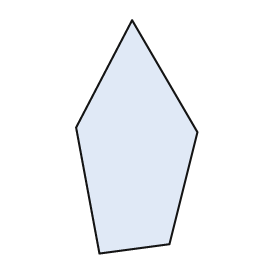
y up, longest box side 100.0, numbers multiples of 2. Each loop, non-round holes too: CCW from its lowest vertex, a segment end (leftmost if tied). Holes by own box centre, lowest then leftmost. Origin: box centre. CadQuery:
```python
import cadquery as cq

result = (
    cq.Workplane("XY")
    .moveTo(-16.0, -50.0)
    .lineTo(14.0, -46.0)
    .lineTo(26.0, 2.0)
    .lineTo(-2.0, 50.0)
    .lineTo(-26.0, 4.0)
    .close()
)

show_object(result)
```